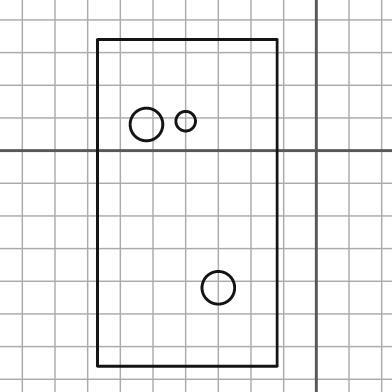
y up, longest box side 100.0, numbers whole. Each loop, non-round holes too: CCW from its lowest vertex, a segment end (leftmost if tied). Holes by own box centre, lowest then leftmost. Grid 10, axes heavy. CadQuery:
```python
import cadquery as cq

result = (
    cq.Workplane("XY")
    .moveTo(-67.0, -66.0)
    .lineTo(-12.0, -66.0)
    .lineTo(-12.0, 34.0)
    .lineTo(-67.0, 34.0)
    .close()
    .moveTo(-30.0, -42.0)
    .circle(5.0)
    .moveTo(-52.0, 8.0)
    .circle(5.0)
    .moveTo(-40.0, 9.0)
    .circle(3.0)
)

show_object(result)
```